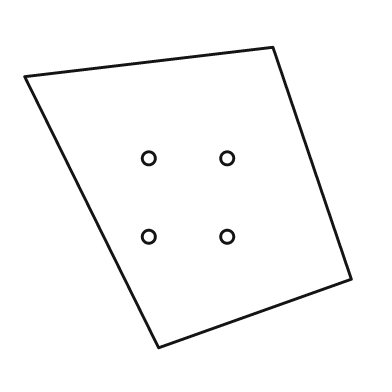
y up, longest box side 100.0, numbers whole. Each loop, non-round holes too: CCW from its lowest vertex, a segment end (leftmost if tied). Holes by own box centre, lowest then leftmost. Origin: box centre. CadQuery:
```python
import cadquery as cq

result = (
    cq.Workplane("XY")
    .moveTo(-9.0, -46.0)
    .lineTo(50.0, -25.0)
    .lineTo(26.0, 46.0)
    .lineTo(-50.0, 37.0)
    .close()
    .moveTo(-12.0, -12.0)
    .circle(2.0)
    .moveTo(12.0, -12.0)
    .circle(2.0)
    .moveTo(-12.0, 12.0)
    .circle(2.0)
    .moveTo(12.0, 12.0)
    .circle(2.0)
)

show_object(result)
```